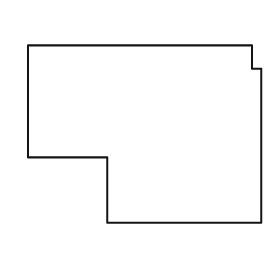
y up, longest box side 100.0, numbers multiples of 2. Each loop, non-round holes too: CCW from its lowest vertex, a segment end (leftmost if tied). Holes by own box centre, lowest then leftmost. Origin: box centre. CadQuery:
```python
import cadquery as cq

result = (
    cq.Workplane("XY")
    .moveTo(-16.0, -38.0)
    .lineTo(50.0, -38.0)
    .lineTo(50.0, 28.0)
    .lineTo(46.0, 28.0)
    .lineTo(46.0, 38.0)
    .lineTo(-50.0, 38.0)
    .lineTo(-50.0, -10.0)
    .lineTo(-16.0, -10.0)
    .close()
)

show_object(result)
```